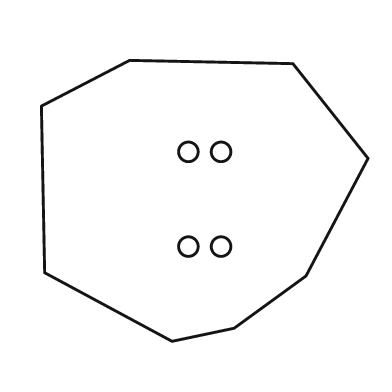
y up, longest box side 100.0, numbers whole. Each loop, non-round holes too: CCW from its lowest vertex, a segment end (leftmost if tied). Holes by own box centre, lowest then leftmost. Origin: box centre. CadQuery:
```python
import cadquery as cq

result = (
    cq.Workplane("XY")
    .moveTo(-10.0, -43.0)
    .lineTo(9.0, -39.0)
    .lineTo(31.0, -23.0)
    .lineTo(50.0, 13.0)
    .lineTo(27.0, 42.0)
    .lineTo(-23.0, 43.0)
    .lineTo(-50.0, 29.0)
    .lineTo(-49.0, -22.0)
    .close()
    .moveTo(-5.0, -14.0)
    .circle(3.0)
    .moveTo(5.0, -14.0)
    .circle(3.0)
    .moveTo(-5.0, 15.0)
    .circle(3.0)
    .moveTo(5.0, 15.0)
    .circle(3.0)
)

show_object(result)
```